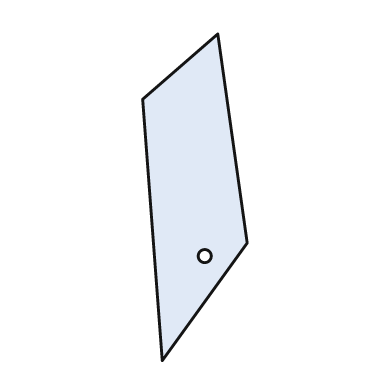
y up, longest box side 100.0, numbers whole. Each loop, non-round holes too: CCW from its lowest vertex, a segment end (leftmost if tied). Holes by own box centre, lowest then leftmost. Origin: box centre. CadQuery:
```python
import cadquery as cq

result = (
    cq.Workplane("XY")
    .moveTo(-10.0, -50.0)
    .lineTo(16.0, -14.0)
    .lineTo(7.0, 50.0)
    .lineTo(-16.0, 30.0)
    .close()
    .moveTo(3.0, -18.0)
    .circle(2.0)
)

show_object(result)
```